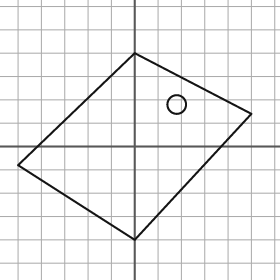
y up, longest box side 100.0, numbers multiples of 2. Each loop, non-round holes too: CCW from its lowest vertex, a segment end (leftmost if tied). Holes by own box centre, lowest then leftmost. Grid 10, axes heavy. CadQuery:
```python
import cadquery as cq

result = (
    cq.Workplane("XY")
    .moveTo(0.0, -40.0)
    .lineTo(50.0, 14.0)
    .lineTo(0.0, 40.0)
    .lineTo(-50.0, -8.0)
    .close()
    .moveTo(18.0, 18.0)
    .circle(4.0)
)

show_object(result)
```